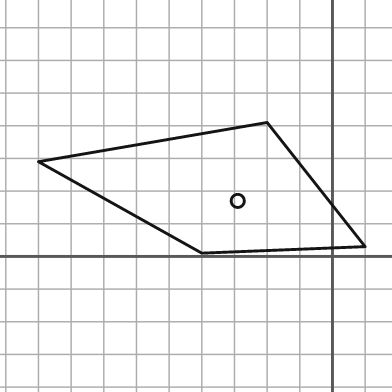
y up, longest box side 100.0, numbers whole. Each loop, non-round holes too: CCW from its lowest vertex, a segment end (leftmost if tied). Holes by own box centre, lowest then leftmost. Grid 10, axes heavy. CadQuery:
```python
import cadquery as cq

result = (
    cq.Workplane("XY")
    .moveTo(-40.0, 1.0)
    .lineTo(10.0, 3.0)
    .lineTo(-20.0, 41.0)
    .lineTo(-90.0, 29.0)
    .close()
    .moveTo(-29.0, 17.0)
    .circle(2.0)
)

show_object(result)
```